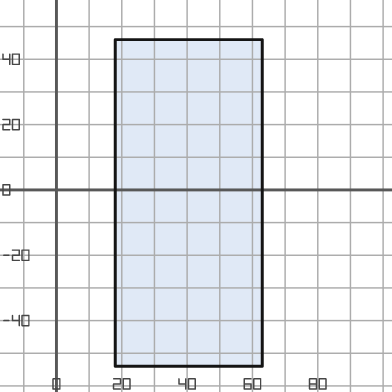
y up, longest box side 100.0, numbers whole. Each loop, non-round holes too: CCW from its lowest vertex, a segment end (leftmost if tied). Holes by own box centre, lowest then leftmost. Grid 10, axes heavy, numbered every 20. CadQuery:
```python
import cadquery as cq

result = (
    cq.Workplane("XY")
    .moveTo(18.0, -54.0)
    .lineTo(63.0, -54.0)
    .lineTo(63.0, 46.0)
    .lineTo(18.0, 46.0)
    .close()
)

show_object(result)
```